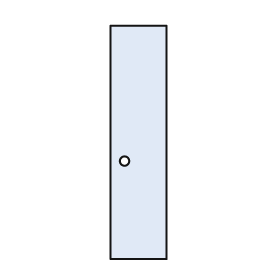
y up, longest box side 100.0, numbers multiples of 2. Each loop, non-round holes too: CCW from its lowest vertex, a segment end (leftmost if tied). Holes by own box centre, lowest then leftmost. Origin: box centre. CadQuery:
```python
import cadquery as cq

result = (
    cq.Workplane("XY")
    .moveTo(-12.0, -50.0)
    .lineTo(12.0, -50.0)
    .lineTo(12.0, 50.0)
    .lineTo(-12.0, 50.0)
    .close()
    .moveTo(-6.0, -8.0)
    .circle(2.0)
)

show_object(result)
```